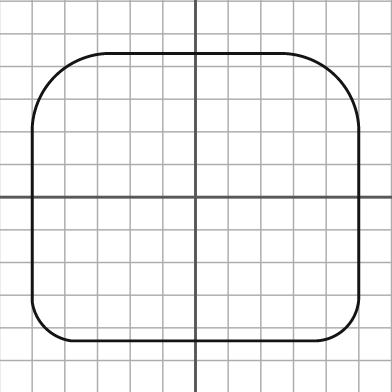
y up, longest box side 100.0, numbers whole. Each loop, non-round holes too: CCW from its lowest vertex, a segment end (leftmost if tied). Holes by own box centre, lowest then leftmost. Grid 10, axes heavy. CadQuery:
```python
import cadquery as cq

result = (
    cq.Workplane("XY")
    .moveTo(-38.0, -44.0)
    .lineTo(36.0, -44.0)
    .threePointArc((46.0, -40.0), (50.0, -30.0))
    .lineTo(50.0, 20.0)
    .threePointArc((43.0, 37.0), (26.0, 44.0))
    .lineTo(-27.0, 44.0)
    .threePointArc((-43.0, 37.0), (-50.0, 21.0))
    .lineTo(-50.0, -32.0)
    .threePointArc((-46.0, -40.0), (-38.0, -44.0))
    .close()
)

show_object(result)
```